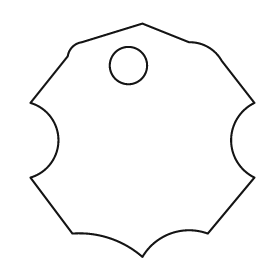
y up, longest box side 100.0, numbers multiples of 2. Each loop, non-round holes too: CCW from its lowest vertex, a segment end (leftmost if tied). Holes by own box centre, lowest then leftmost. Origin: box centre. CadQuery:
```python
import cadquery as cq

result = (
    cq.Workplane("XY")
    .moveTo(0.0, -50.0)
    .threePointArc((12.0, -40.0), (28.0, -40.0))
    .lineTo(48.0, -16.0)
    .threePointArc((38.0, 0.0), (48.0, 16.0))
    .lineTo(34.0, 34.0)
    .threePointArc((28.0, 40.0), (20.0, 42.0))
    .lineTo(0.0, 50.0)
    .lineTo(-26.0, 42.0)
    .threePointArc((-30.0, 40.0), (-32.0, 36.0))
    .lineTo(-48.0, 16.0)
    .threePointArc((-36.0, 0.0), (-48.0, -16.0))
    .lineTo(-30.0, -40.0)
    .threePointArc((-14.0, -42.0), (0.0, -50.0))
    .close()
    .moveTo(-6.0, 32.0)
    .circle(8.0)
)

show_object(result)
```